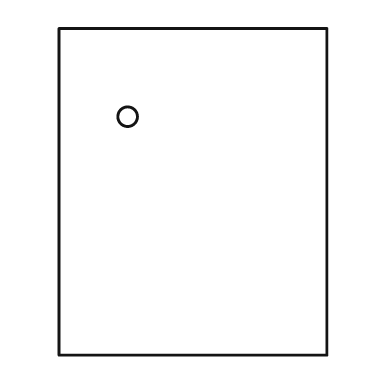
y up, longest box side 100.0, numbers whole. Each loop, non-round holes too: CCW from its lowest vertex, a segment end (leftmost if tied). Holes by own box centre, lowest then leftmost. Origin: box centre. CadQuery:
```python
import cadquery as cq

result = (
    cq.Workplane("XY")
    .moveTo(-41.0, -50.0)
    .lineTo(41.0, -50.0)
    .lineTo(41.0, 50.0)
    .lineTo(-41.0, 50.0)
    .close()
    .moveTo(-20.0, 23.0)
    .circle(3.0)
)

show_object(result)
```